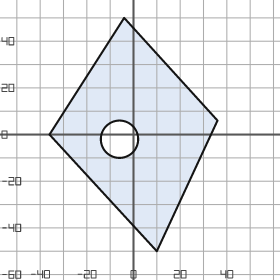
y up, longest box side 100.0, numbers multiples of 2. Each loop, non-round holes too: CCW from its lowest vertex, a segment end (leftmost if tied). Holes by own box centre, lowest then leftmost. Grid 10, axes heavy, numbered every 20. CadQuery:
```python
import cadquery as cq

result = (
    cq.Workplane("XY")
    .moveTo(10.0, -50.0)
    .lineTo(36.0, 6.0)
    .lineTo(-4.0, 50.0)
    .lineTo(-36.0, 0.0)
    .close()
    .moveTo(-6.0, -2.0)
    .circle(8.0)
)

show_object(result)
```